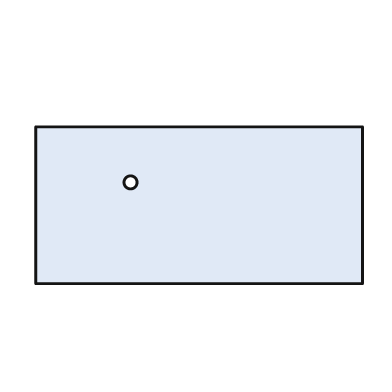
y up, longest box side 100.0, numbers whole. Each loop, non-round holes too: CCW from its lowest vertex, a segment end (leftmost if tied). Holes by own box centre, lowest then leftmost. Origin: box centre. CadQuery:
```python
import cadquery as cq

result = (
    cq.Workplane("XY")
    .moveTo(-50.0, -24.0)
    .lineTo(50.0, -24.0)
    .lineTo(50.0, 24.0)
    .lineTo(-50.0, 24.0)
    .close()
    .moveTo(-21.0, 7.0)
    .circle(2.0)
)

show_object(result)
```